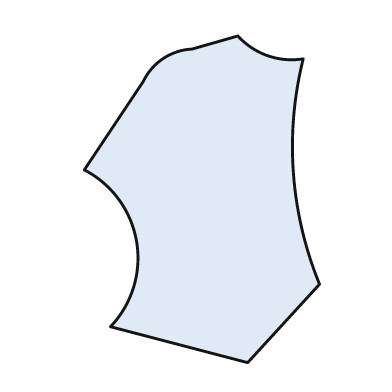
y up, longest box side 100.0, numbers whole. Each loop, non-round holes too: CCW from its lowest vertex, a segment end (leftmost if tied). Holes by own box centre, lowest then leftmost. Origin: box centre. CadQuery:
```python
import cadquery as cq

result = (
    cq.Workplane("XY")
    .moveTo(14.0, -50.0)
    .lineTo(36.0, -26.0)
    .threePointArc((28.0, 8.0), (31.0, 43.0))
    .threePointArc((20.0, 44.0), (11.0, 50.0))
    .lineTo(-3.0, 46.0)
    .threePointArc((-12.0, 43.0), (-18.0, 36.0))
    .lineTo(-36.0, 9.0)
    .threePointArc((-20.0, -13.0), (-28.0, -39.0))
    .close()
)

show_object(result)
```